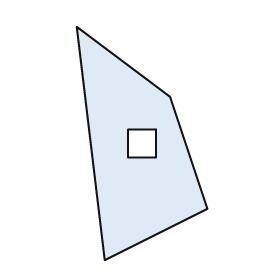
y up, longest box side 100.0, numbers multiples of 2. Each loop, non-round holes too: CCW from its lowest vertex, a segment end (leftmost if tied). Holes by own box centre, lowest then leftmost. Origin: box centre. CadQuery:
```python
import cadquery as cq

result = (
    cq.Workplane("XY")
    .moveTo(-16.0, -50.0)
    .lineTo(28.0, -28.0)
    .lineTo(12.0, 20.0)
    .lineTo(-28.0, 50.0)
    .close()
    .moveTo(-6.0, -6.0)
    .lineTo(6.0, -6.0)
    .lineTo(6.0, 6.0)
    .lineTo(-6.0, 6.0)
    .close()
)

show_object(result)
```